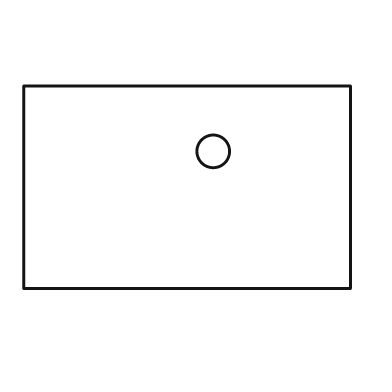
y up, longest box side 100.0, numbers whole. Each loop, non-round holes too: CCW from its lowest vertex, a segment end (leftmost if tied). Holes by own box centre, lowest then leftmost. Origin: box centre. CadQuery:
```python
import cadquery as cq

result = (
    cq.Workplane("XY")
    .moveTo(-50.0, -31.0)
    .lineTo(50.0, -31.0)
    .lineTo(50.0, 31.0)
    .lineTo(-50.0, 31.0)
    .close()
    .moveTo(8.0, 11.0)
    .circle(5.0)
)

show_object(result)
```